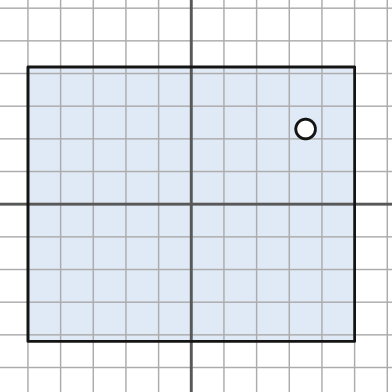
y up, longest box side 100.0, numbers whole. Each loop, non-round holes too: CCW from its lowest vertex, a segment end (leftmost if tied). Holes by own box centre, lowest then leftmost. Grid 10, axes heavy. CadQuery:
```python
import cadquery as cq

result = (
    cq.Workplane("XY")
    .moveTo(-50.0, -42.0)
    .lineTo(50.0, -42.0)
    .lineTo(50.0, 42.0)
    .lineTo(-50.0, 42.0)
    .close()
    .moveTo(35.0, 23.0)
    .circle(3.0)
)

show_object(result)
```